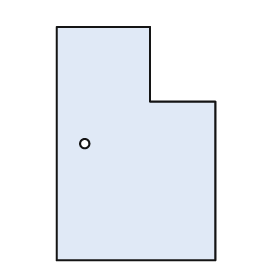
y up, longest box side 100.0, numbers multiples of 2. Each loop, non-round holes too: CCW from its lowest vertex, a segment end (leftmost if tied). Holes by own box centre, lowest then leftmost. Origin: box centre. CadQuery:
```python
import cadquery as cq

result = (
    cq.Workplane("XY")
    .moveTo(-34.0, -50.0)
    .lineTo(34.0, -50.0)
    .lineTo(34.0, 18.0)
    .lineTo(6.0, 18.0)
    .lineTo(6.0, 50.0)
    .lineTo(-34.0, 50.0)
    .close()
    .moveTo(-22.0, 0.0)
    .circle(2.0)
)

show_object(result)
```